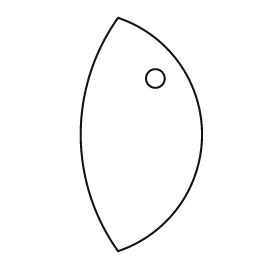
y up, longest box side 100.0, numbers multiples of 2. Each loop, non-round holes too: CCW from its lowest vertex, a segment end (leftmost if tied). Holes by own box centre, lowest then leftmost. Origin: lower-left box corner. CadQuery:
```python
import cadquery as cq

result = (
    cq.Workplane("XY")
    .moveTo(16.0, 0.0)
    .threePointArc((52.0, 50.0), (16.0, 100.0))
    .threePointArc((0.0, 50.0), (16.0, 0.0))
    .close()
    .moveTo(32.0, 74.0)
    .circle(4.0)
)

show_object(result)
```